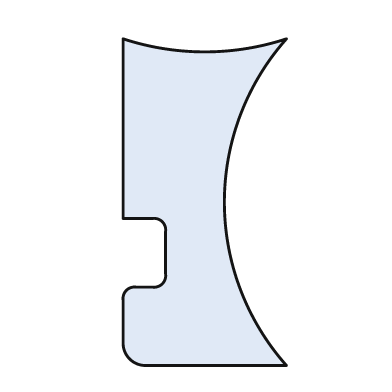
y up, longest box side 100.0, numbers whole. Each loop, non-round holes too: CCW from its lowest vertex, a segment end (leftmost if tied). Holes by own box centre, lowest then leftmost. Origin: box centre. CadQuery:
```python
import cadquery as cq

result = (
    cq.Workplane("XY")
    .moveTo(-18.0, -50.0)
    .lineTo(25.0, -50.0)
    .threePointArc((6.0, 0.0), (25.0, 50.0))
    .threePointArc((0.0, 46.0), (-25.0, 50.0))
    .lineTo(-25.0, -5.0)
    .lineTo(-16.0, -5.0)
    .threePointArc((-13.0, -6.0), (-12.0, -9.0))
    .lineTo(-12.0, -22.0)
    .threePointArc((-13.0, -25.0), (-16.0, -26.0))
    .lineTo(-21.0, -26.0)
    .threePointArc((-24.0, -27.0), (-25.0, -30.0))
    .lineTo(-25.0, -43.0)
    .threePointArc((-23.0, -48.0), (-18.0, -50.0))
    .close()
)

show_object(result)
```